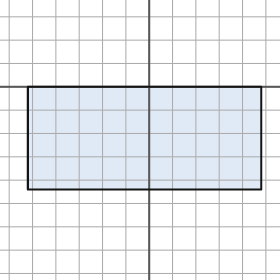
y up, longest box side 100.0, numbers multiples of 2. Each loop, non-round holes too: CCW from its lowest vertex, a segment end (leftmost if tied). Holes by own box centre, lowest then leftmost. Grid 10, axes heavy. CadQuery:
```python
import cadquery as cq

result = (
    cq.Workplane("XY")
    .moveTo(-52.0, -44.0)
    .lineTo(48.0, -44.0)
    .lineTo(48.0, 0.0)
    .lineTo(-52.0, 0.0)
    .close()
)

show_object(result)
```